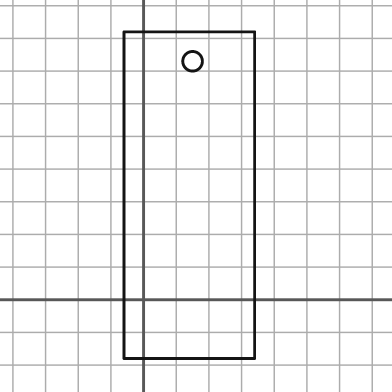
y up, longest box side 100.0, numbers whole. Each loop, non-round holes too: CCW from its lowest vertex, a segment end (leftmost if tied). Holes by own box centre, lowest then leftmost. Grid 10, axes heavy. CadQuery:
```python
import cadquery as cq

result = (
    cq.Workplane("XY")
    .moveTo(-6.0, -18.0)
    .lineTo(34.0, -18.0)
    .lineTo(34.0, 82.0)
    .lineTo(-6.0, 82.0)
    .close()
    .moveTo(15.0, 73.0)
    .circle(3.0)
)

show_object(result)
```